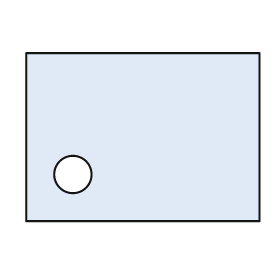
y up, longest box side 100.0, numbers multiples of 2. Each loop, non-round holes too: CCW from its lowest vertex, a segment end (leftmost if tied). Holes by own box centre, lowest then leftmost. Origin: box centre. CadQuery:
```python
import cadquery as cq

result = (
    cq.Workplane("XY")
    .moveTo(-50.0, -36.0)
    .lineTo(50.0, -36.0)
    .lineTo(50.0, 36.0)
    .lineTo(-50.0, 36.0)
    .close()
    .moveTo(-30.0, -16.0)
    .circle(8.0)
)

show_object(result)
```